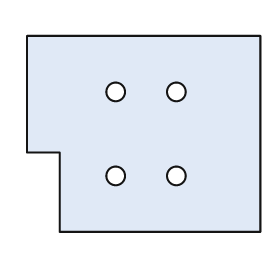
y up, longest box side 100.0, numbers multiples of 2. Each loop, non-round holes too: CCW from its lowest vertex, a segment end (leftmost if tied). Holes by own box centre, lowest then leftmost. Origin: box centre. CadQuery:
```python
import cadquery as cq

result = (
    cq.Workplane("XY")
    .moveTo(-36.0, -42.0)
    .lineTo(50.0, -42.0)
    .lineTo(50.0, 42.0)
    .lineTo(-50.0, 42.0)
    .lineTo(-50.0, -8.0)
    .lineTo(-36.0, -8.0)
    .close()
    .moveTo(-12.0, -18.0)
    .circle(4.0)
    .moveTo(14.0, -18.0)
    .circle(4.0)
    .moveTo(-12.0, 18.0)
    .circle(4.0)
    .moveTo(14.0, 18.0)
    .circle(4.0)
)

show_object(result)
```